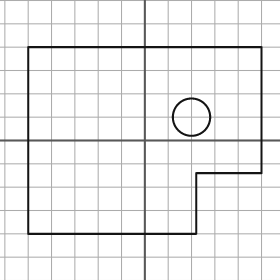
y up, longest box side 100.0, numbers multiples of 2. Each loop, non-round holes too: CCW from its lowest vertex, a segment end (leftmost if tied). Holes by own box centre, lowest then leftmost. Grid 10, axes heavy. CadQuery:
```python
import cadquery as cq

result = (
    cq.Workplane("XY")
    .moveTo(-50.0, -40.0)
    .lineTo(22.0, -40.0)
    .lineTo(22.0, -14.0)
    .lineTo(50.0, -14.0)
    .lineTo(50.0, 40.0)
    .lineTo(-50.0, 40.0)
    .close()
    .moveTo(20.0, 10.0)
    .circle(8.0)
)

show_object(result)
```